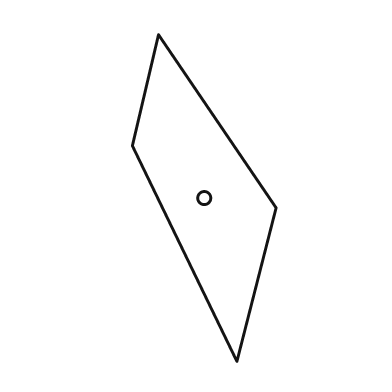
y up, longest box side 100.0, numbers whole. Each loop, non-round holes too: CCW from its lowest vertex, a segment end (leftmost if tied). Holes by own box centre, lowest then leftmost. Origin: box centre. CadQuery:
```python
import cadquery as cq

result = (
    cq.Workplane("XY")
    .moveTo(10.0, -50.0)
    .lineTo(22.0, -3.0)
    .lineTo(-14.0, 50.0)
    .lineTo(-22.0, 16.0)
    .close()
    .moveTo(0.0, 0.0)
    .circle(2.0)
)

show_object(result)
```